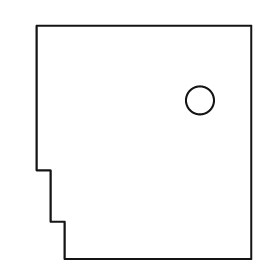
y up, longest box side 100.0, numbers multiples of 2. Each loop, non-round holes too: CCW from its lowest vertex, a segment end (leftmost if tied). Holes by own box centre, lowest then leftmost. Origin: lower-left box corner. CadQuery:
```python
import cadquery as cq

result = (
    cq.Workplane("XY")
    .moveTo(12.0, 0.0)
    .lineTo(92.0, 0.0)
    .lineTo(92.0, 100.0)
    .lineTo(0.0, 100.0)
    .lineTo(0.0, 38.0)
    .lineTo(6.0, 38.0)
    .lineTo(6.0, 16.0)
    .lineTo(12.0, 16.0)
    .close()
    .moveTo(70.0, 68.0)
    .circle(6.0)
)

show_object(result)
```